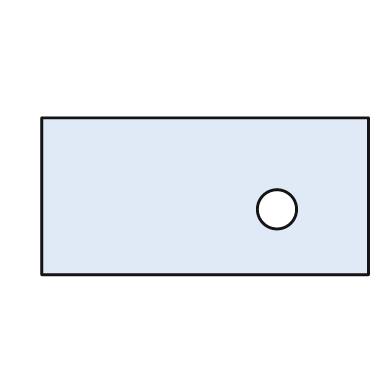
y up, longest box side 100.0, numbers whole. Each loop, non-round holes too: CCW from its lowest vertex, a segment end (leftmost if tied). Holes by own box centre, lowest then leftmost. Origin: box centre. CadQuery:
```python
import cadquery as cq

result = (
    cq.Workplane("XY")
    .moveTo(-50.0, -24.0)
    .lineTo(50.0, -24.0)
    .lineTo(50.0, 24.0)
    .lineTo(-50.0, 24.0)
    .close()
    .moveTo(22.0, -4.0)
    .circle(6.0)
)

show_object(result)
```